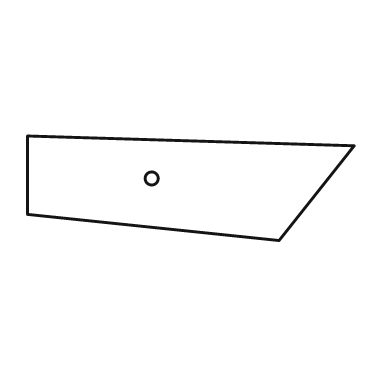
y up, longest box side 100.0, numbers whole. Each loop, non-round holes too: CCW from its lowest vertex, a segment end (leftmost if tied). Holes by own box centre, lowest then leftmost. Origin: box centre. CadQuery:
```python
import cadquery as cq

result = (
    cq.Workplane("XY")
    .moveTo(27.0, -16.0)
    .lineTo(50.0, 13.0)
    .lineTo(-50.0, 16.0)
    .lineTo(-50.0, -8.0)
    .close()
    .moveTo(-12.0, 3.0)
    .circle(2.0)
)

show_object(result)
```